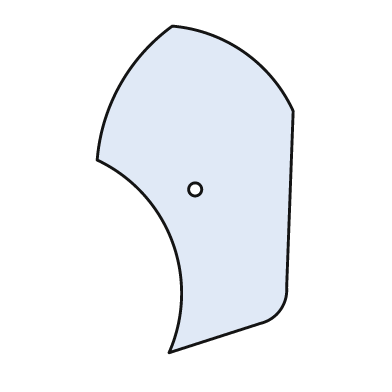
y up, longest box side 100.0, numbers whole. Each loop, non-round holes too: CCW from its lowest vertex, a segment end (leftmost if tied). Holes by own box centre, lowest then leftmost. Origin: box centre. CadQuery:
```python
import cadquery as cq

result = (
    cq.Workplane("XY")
    .moveTo(-8.0, -50.0)
    .lineTo(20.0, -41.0)
    .threePointArc((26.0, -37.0), (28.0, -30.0))
    .lineTo(30.0, 24.0)
    .threePointArc((15.0, 42.0), (-7.0, 50.0))
    .threePointArc((-23.0, 32.0), (-30.0, 9.0))
    .threePointArc((-7.0, -16.0), (-8.0, -50.0))
    .close()
    .moveTo(0.0, 0.0)
    .circle(2.0)
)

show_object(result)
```